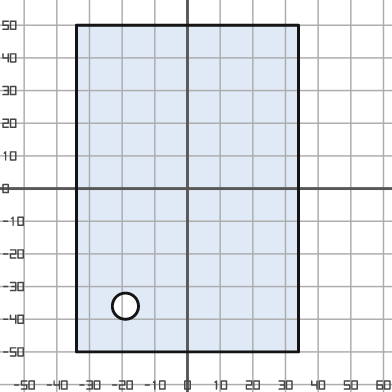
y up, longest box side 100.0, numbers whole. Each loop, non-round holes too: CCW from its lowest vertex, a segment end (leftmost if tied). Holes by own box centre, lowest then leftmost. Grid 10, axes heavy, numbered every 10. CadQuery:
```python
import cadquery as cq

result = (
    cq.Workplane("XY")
    .moveTo(-34.0, -50.0)
    .lineTo(34.0, -50.0)
    .lineTo(34.0, 50.0)
    .lineTo(-34.0, 50.0)
    .close()
    .moveTo(-19.0, -36.0)
    .circle(4.0)
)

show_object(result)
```